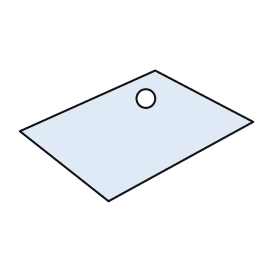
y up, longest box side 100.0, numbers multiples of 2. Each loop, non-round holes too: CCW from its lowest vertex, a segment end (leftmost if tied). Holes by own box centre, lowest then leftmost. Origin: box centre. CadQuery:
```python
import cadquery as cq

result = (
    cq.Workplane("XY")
    .moveTo(-12.0, -28.0)
    .lineTo(50.0, 6.0)
    .lineTo(8.0, 28.0)
    .lineTo(-50.0, 2.0)
    .close()
    .moveTo(4.0, 16.0)
    .circle(4.0)
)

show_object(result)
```